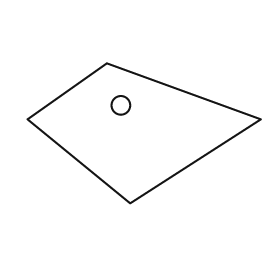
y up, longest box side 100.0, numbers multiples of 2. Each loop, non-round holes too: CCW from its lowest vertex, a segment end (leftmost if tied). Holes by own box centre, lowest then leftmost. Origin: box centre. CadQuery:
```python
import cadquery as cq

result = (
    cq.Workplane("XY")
    .moveTo(-6.0, -30.0)
    .lineTo(50.0, 6.0)
    .lineTo(-16.0, 30.0)
    .lineTo(-50.0, 6.0)
    .close()
    .moveTo(-10.0, 12.0)
    .circle(4.0)
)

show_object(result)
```